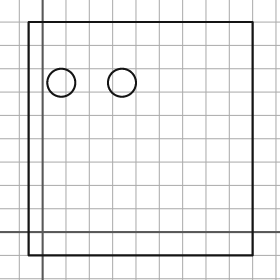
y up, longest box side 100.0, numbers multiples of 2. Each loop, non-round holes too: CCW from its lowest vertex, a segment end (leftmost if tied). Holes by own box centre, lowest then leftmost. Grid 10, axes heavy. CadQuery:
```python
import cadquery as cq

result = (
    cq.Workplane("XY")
    .moveTo(-6.0, -10.0)
    .lineTo(90.0, -10.0)
    .lineTo(90.0, 90.0)
    .lineTo(-6.0, 90.0)
    .close()
    .moveTo(8.0, 64.0)
    .circle(6.0)
    .moveTo(34.0, 64.0)
    .circle(6.0)
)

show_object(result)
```